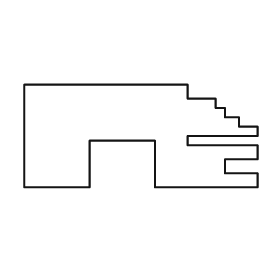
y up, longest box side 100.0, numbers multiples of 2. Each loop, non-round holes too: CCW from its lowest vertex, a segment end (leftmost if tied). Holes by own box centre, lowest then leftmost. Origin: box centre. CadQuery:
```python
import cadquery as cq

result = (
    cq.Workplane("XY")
    .moveTo(-50.0, -22.0)
    .lineTo(-22.0, -22.0)
    .lineTo(-22.0, -2.0)
    .lineTo(6.0, -2.0)
    .lineTo(6.0, -22.0)
    .lineTo(50.0, -22.0)
    .lineTo(50.0, -16.0)
    .lineTo(36.0, -16.0)
    .lineTo(36.0, -10.0)
    .lineTo(50.0, -10.0)
    .lineTo(50.0, -4.0)
    .lineTo(20.0, -4.0)
    .lineTo(20.0, 0.0)
    .lineTo(50.0, 0.0)
    .lineTo(50.0, 4.0)
    .lineTo(42.0, 4.0)
    .lineTo(42.0, 8.0)
    .lineTo(36.0, 8.0)
    .lineTo(36.0, 12.0)
    .lineTo(32.0, 12.0)
    .lineTo(32.0, 16.0)
    .lineTo(20.0, 16.0)
    .lineTo(20.0, 22.0)
    .lineTo(-50.0, 22.0)
    .close()
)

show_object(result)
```